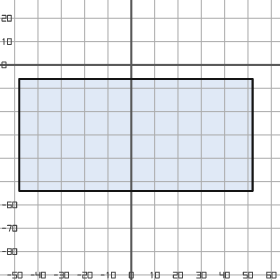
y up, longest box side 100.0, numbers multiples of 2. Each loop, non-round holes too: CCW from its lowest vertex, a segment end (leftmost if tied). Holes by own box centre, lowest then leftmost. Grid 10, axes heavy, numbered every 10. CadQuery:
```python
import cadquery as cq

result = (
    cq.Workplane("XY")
    .moveTo(-48.0, -54.0)
    .lineTo(52.0, -54.0)
    .lineTo(52.0, -6.0)
    .lineTo(-48.0, -6.0)
    .close()
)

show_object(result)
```